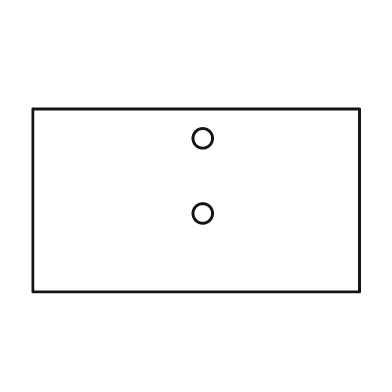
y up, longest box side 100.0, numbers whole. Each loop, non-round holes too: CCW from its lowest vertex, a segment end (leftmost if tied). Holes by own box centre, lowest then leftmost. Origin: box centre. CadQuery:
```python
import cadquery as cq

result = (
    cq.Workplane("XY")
    .moveTo(-50.0, -28.0)
    .lineTo(50.0, -28.0)
    .lineTo(50.0, 28.0)
    .lineTo(-50.0, 28.0)
    .close()
    .moveTo(2.0, -4.0)
    .circle(3.0)
    .moveTo(2.0, 19.0)
    .circle(3.0)
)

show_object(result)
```